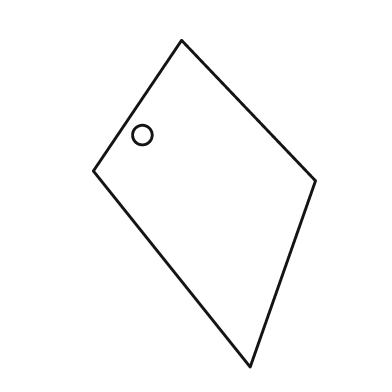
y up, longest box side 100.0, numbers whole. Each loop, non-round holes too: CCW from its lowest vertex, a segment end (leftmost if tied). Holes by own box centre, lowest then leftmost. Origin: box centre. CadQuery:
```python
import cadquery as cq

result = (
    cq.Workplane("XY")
    .moveTo(14.0, -50.0)
    .lineTo(34.0, 7.0)
    .lineTo(-7.0, 50.0)
    .lineTo(-34.0, 10.0)
    .close()
    .moveTo(-19.0, 21.0)
    .circle(3.0)
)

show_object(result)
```